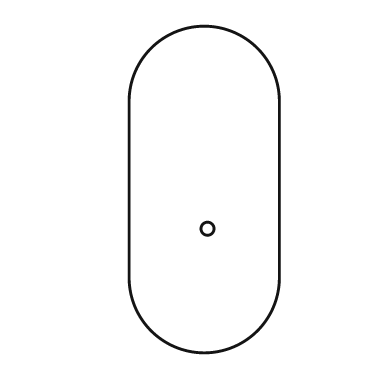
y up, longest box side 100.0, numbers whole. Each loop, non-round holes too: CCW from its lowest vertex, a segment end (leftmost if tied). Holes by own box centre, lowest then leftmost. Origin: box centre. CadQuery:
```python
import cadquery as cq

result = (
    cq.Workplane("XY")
    .moveTo(-23.0, -27.0)
    .threePointArc((0.0, -50.0), (23.0, -27.0))
    .lineTo(23.0, 27.0)
    .threePointArc((0.0, 50.0), (-23.0, 27.0))
    .close()
    .moveTo(1.0, -12.0)
    .circle(2.0)
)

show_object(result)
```